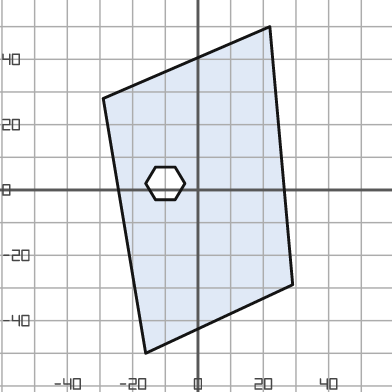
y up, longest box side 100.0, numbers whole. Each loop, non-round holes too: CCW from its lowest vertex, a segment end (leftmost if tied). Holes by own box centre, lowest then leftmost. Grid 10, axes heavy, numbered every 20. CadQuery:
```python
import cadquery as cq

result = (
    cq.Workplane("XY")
    .moveTo(-16.0, -50.0)
    .lineTo(29.0, -29.0)
    .lineTo(22.0, 50.0)
    .lineTo(-29.0, 28.0)
    .close()
    .moveTo(-13.0, -3.0)
    .lineTo(-7.0, -3.0)
    .lineTo(-4.0, 2.0)
    .lineTo(-7.0, 7.0)
    .lineTo(-13.0, 7.0)
    .lineTo(-16.0, 2.0)
    .close()
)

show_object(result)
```